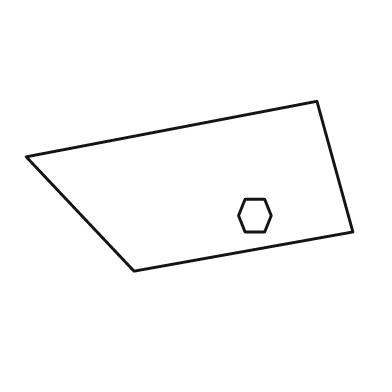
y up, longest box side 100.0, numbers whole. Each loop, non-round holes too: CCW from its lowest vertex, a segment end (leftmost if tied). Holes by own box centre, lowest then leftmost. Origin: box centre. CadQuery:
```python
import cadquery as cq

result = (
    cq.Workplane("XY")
    .moveTo(-17.0, -26.0)
    .lineTo(50.0, -14.0)
    .lineTo(39.0, 26.0)
    .lineTo(-50.0, 9.0)
    .close()
    .moveTo(17.0, -14.0)
    .lineTo(23.0, -14.0)
    .lineTo(25.0, -9.0)
    .lineTo(23.0, -4.0)
    .lineTo(17.0, -4.0)
    .lineTo(15.0, -9.0)
    .close()
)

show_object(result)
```